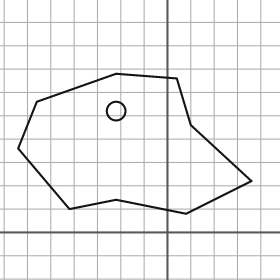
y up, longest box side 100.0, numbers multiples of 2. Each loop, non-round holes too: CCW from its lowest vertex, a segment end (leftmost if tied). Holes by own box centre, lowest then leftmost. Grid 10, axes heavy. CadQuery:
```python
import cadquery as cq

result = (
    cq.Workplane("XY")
    .moveTo(8.0, 8.0)
    .lineTo(36.0, 22.0)
    .lineTo(10.0, 46.0)
    .lineTo(4.0, 66.0)
    .lineTo(-22.0, 68.0)
    .lineTo(-56.0, 56.0)
    .lineTo(-64.0, 36.0)
    .lineTo(-42.0, 10.0)
    .lineTo(-22.0, 14.0)
    .close()
    .moveTo(-22.0, 52.0)
    .circle(4.0)
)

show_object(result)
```